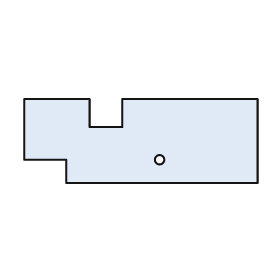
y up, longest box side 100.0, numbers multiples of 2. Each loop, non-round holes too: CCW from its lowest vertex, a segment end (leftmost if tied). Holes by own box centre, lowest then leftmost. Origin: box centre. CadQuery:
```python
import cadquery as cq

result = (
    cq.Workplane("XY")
    .moveTo(-32.0, -18.0)
    .lineTo(50.0, -18.0)
    .lineTo(50.0, 18.0)
    .lineTo(-8.0, 18.0)
    .lineTo(-8.0, 6.0)
    .lineTo(-22.0, 6.0)
    .lineTo(-22.0, 18.0)
    .lineTo(-50.0, 18.0)
    .lineTo(-50.0, -8.0)
    .lineTo(-32.0, -8.0)
    .close()
    .moveTo(8.0, -8.0)
    .circle(2.0)
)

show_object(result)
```